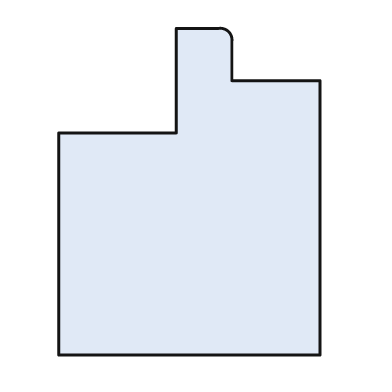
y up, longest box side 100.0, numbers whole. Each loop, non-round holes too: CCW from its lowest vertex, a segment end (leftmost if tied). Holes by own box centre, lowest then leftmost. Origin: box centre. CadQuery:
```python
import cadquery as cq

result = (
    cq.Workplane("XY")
    .moveTo(-40.0, -50.0)
    .lineTo(40.0, -50.0)
    .lineTo(40.0, 34.0)
    .lineTo(13.0, 34.0)
    .lineTo(13.0, 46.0)
    .threePointArc((12.0, 49.0), (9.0, 50.0))
    .lineTo(-4.0, 50.0)
    .lineTo(-4.0, 18.0)
    .lineTo(-40.0, 18.0)
    .close()
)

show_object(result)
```